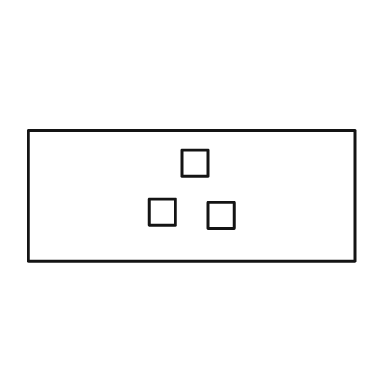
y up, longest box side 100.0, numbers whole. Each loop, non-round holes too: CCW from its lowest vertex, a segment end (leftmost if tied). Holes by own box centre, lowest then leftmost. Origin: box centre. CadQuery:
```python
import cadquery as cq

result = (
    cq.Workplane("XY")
    .moveTo(-50.0, -20.0)
    .lineTo(50.0, -20.0)
    .lineTo(50.0, 20.0)
    .lineTo(-50.0, 20.0)
    .close()
    .moveTo(5.0, -10.0)
    .lineTo(13.0, -10.0)
    .lineTo(13.0, -2.0)
    .lineTo(5.0, -2.0)
    .close()
    .moveTo(-13.0, -9.0)
    .lineTo(-5.0, -9.0)
    .lineTo(-5.0, -1.0)
    .lineTo(-13.0, -1.0)
    .close()
    .moveTo(-3.0, 6.0)
    .lineTo(5.0, 6.0)
    .lineTo(5.0, 14.0)
    .lineTo(-3.0, 14.0)
    .close()
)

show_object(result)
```